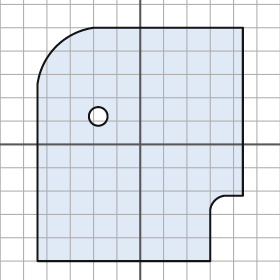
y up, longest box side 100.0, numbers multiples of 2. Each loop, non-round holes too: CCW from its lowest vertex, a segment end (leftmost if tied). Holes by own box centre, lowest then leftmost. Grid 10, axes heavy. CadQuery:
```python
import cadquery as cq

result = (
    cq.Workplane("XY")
    .moveTo(-44.0, -50.0)
    .lineTo(30.0, -50.0)
    .lineTo(30.0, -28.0)
    .threePointArc((32.0, -24.0), (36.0, -22.0))
    .lineTo(44.0, -22.0)
    .lineTo(44.0, 50.0)
    .lineTo(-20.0, 50.0)
    .threePointArc((-36.0, 42.0), (-44.0, 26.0))
    .close()
    .moveTo(-18.0, 12.0)
    .circle(4.0)
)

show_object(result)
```